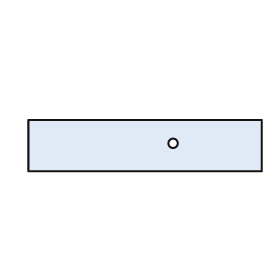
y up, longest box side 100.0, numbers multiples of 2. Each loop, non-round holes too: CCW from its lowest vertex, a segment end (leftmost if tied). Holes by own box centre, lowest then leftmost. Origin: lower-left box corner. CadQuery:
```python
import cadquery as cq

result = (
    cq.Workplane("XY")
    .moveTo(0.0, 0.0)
    .lineTo(100.0, 0.0)
    .lineTo(100.0, 22.0)
    .lineTo(0.0, 22.0)
    .close()
    .moveTo(62.0, 12.0)
    .circle(2.0)
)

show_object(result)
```